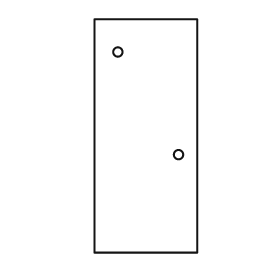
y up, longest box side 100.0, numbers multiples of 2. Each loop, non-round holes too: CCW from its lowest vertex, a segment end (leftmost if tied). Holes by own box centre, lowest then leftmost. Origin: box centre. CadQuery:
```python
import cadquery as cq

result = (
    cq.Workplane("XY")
    .moveTo(-22.0, -50.0)
    .lineTo(22.0, -50.0)
    .lineTo(22.0, 50.0)
    .lineTo(-22.0, 50.0)
    .close()
    .moveTo(14.0, -8.0)
    .circle(2.0)
    .moveTo(-12.0, 36.0)
    .circle(2.0)
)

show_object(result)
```